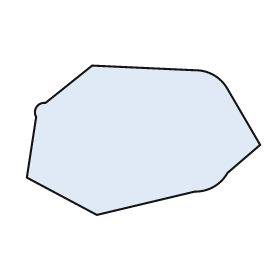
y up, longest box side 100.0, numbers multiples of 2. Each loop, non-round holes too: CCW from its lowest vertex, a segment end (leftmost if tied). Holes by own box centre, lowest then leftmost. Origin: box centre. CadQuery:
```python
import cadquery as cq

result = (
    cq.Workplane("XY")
    .moveTo(-20.0, -32.0)
    .lineTo(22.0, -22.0)
    .threePointArc((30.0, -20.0), (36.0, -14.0))
    .lineTo(50.0, -2.0)
    .lineTo(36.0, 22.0)
    .threePointArc((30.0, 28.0), (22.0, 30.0))
    .lineTo(-22.0, 32.0)
    .lineTo(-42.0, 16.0)
    .threePointArc((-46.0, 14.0), (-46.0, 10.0))
    .lineTo(-50.0, -16.0)
    .close()
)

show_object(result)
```